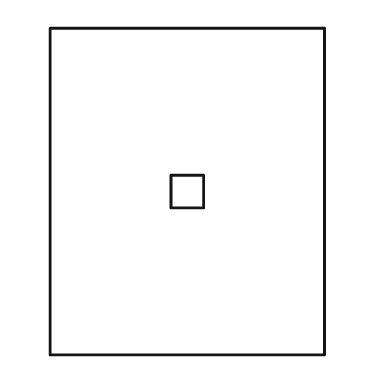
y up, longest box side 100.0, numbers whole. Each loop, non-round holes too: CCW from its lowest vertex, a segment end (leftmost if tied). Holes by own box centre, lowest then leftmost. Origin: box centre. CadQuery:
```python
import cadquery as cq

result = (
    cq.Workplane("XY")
    .moveTo(-42.0, -50.0)
    .lineTo(42.0, -50.0)
    .lineTo(42.0, 50.0)
    .lineTo(-42.0, 50.0)
    .close()
    .moveTo(-5.0, -5.0)
    .lineTo(5.0, -5.0)
    .lineTo(5.0, 5.0)
    .lineTo(-5.0, 5.0)
    .close()
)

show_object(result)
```